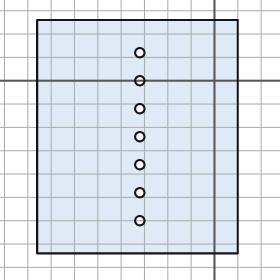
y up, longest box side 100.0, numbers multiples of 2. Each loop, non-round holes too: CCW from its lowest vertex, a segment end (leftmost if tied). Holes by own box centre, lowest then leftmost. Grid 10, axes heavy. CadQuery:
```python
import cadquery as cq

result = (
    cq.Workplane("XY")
    .moveTo(-76.0, -74.0)
    .lineTo(10.0, -74.0)
    .lineTo(10.0, 26.0)
    .lineTo(-76.0, 26.0)
    .close()
    .moveTo(-32.0, -60.0)
    .circle(2.0)
    .moveTo(-32.0, -48.0)
    .circle(2.0)
    .moveTo(-32.0, -36.0)
    .circle(2.0)
    .moveTo(-32.0, -24.0)
    .circle(2.0)
    .moveTo(-32.0, -12.0)
    .circle(2.0)
    .moveTo(-32.0, 0.0)
    .circle(2.0)
    .moveTo(-32.0, 12.0)
    .circle(2.0)
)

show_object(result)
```